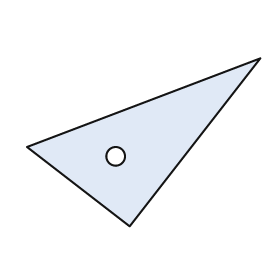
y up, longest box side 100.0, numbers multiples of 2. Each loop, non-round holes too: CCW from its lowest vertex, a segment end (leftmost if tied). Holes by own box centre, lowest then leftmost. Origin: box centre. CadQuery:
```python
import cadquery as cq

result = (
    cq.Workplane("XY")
    .moveTo(-6.0, -36.0)
    .lineTo(50.0, 36.0)
    .lineTo(-50.0, -2.0)
    .close()
    .moveTo(-12.0, -6.0)
    .circle(4.0)
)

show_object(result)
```